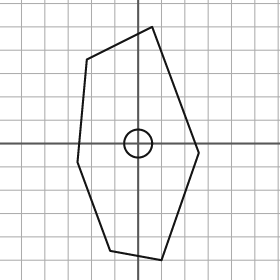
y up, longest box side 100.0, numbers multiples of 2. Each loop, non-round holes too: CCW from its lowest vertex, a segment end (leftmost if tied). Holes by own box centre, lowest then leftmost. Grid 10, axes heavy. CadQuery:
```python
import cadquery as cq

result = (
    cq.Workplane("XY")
    .moveTo(10.0, -50.0)
    .lineTo(26.0, -4.0)
    .lineTo(6.0, 50.0)
    .lineTo(-22.0, 36.0)
    .lineTo(-26.0, -8.0)
    .lineTo(-12.0, -46.0)
    .close()
    .moveTo(0.0, 0.0)
    .circle(6.0)
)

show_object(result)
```